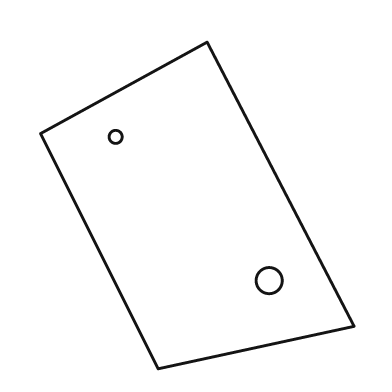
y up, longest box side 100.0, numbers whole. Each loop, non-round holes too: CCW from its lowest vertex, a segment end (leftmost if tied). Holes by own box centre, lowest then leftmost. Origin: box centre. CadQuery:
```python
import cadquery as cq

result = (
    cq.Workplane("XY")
    .moveTo(-12.0, -50.0)
    .lineTo(48.0, -37.0)
    .lineTo(3.0, 50.0)
    .lineTo(-48.0, 22.0)
    .close()
    .moveTo(22.0, -23.0)
    .circle(4.0)
    .moveTo(-25.0, 21.0)
    .circle(2.0)
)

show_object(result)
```